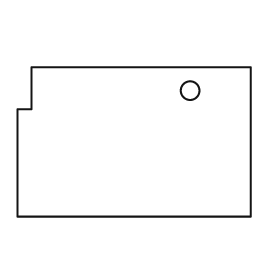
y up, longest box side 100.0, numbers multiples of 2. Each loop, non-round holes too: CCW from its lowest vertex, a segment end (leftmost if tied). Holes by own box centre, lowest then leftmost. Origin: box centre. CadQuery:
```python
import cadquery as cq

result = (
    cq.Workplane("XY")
    .moveTo(-50.0, -32.0)
    .lineTo(50.0, -32.0)
    .lineTo(50.0, 32.0)
    .lineTo(-44.0, 32.0)
    .lineTo(-44.0, 14.0)
    .lineTo(-50.0, 14.0)
    .close()
    .moveTo(24.0, 22.0)
    .circle(4.0)
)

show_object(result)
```